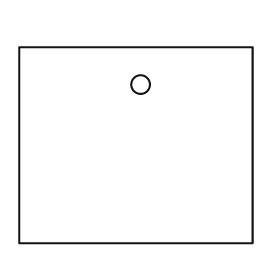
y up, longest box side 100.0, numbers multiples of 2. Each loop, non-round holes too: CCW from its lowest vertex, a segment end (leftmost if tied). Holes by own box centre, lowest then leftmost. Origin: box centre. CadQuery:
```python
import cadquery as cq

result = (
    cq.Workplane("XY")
    .moveTo(-50.0, -42.0)
    .lineTo(50.0, -42.0)
    .lineTo(50.0, 42.0)
    .lineTo(-50.0, 42.0)
    .close()
    .moveTo(2.0, 26.0)
    .circle(4.0)
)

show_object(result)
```